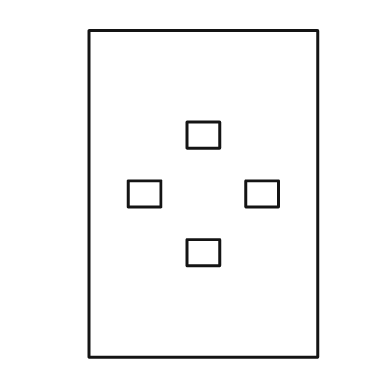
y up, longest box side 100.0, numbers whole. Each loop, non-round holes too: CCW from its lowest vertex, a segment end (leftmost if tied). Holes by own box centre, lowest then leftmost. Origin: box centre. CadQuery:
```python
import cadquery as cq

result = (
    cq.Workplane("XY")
    .moveTo(-35.0, -50.0)
    .lineTo(35.0, -50.0)
    .lineTo(35.0, 50.0)
    .lineTo(-35.0, 50.0)
    .close()
    .moveTo(-5.0, -22.0)
    .lineTo(5.0, -22.0)
    .lineTo(5.0, -14.0)
    .lineTo(-5.0, -14.0)
    .close()
    .moveTo(-23.0, -4.0)
    .lineTo(-13.0, -4.0)
    .lineTo(-13.0, 4.0)
    .lineTo(-23.0, 4.0)
    .close()
    .moveTo(13.0, -4.0)
    .lineTo(23.0, -4.0)
    .lineTo(23.0, 4.0)
    .lineTo(13.0, 4.0)
    .close()
    .moveTo(-5.0, 14.0)
    .lineTo(5.0, 14.0)
    .lineTo(5.0, 22.0)
    .lineTo(-5.0, 22.0)
    .close()
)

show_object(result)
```